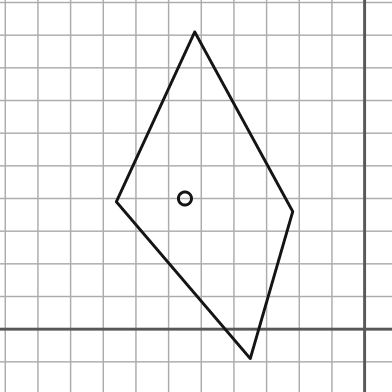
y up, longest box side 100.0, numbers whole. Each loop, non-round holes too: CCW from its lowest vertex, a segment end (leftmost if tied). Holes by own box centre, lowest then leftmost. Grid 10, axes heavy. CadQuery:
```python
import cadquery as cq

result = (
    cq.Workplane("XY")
    .moveTo(-35.0, -9.0)
    .lineTo(-22.0, 36.0)
    .lineTo(-52.0, 91.0)
    .lineTo(-76.0, 39.0)
    .close()
    .moveTo(-55.0, 40.0)
    .circle(2.0)
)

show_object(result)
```